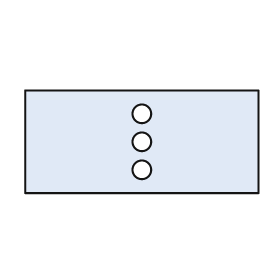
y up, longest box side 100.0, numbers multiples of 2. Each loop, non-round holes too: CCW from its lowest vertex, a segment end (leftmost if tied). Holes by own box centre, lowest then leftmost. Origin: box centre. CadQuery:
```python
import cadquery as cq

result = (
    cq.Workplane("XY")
    .moveTo(-50.0, -22.0)
    .lineTo(50.0, -22.0)
    .lineTo(50.0, 22.0)
    .lineTo(-50.0, 22.0)
    .close()
    .moveTo(0.0, -12.0)
    .circle(4.0)
    .moveTo(0.0, 0.0)
    .circle(4.0)
    .moveTo(0.0, 12.0)
    .circle(4.0)
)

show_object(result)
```